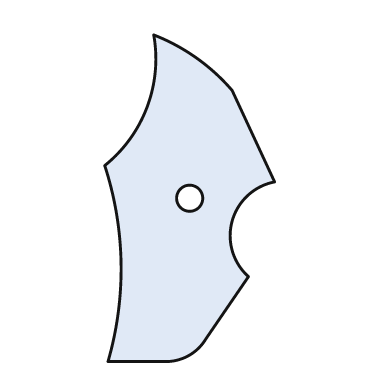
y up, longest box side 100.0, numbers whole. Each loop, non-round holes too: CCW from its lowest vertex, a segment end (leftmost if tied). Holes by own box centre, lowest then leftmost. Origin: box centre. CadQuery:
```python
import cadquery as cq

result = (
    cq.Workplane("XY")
    .moveTo(-25.0, -50.0)
    .lineTo(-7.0, -50.0)
    .threePointArc((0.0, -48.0), (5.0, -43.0))
    .lineTo(18.0, -24.0)
    .threePointArc((13.0, -7.0), (26.0, 5.0))
    .lineTo(13.0, 33.0)
    .threePointArc((2.0, 43.0), (-11.0, 50.0))
    .threePointArc((-13.0, 28.0), (-26.0, 10.0))
    .threePointArc((-21.0, -20.0), (-25.0, -50.0))
    .close()
    .moveTo(0.0, 0.0)
    .circle(4.0)
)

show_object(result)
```